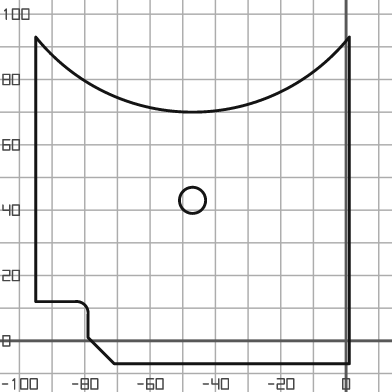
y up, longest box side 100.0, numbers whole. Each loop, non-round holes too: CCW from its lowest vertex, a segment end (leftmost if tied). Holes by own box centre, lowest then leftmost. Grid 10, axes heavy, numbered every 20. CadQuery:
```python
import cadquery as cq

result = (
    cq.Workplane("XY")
    .moveTo(-71.0, -7.0)
    .lineTo(1.0, -7.0)
    .lineTo(1.0, 93.0)
    .threePointArc((-47.0, 70.0), (-95.0, 93.0))
    .lineTo(-95.0, 12.0)
    .lineTo(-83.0, 12.0)
    .threePointArc((-80.0, 11.0), (-79.0, 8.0))
    .lineTo(-79.0, 1.0)
    .close()
    .moveTo(-47.0, 43.0)
    .circle(4.0)
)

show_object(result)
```